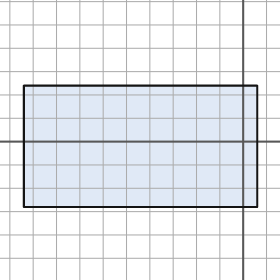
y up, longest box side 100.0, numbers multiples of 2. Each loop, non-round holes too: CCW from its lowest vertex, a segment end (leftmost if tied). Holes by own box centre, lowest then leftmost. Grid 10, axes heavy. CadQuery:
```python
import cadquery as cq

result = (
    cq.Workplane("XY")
    .moveTo(-94.0, -28.0)
    .lineTo(6.0, -28.0)
    .lineTo(6.0, 24.0)
    .lineTo(-94.0, 24.0)
    .close()
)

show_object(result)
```